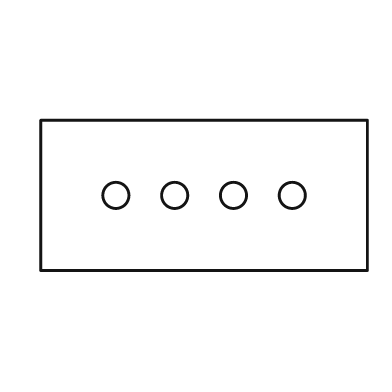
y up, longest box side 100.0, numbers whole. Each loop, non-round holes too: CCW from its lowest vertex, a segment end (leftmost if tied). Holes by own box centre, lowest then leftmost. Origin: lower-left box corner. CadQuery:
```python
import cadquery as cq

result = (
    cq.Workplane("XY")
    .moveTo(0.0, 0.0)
    .lineTo(100.0, 0.0)
    .lineTo(100.0, 46.0)
    .lineTo(0.0, 46.0)
    .close()
    .moveTo(23.0, 23.0)
    .circle(4.0)
    .moveTo(41.0, 23.0)
    .circle(4.0)
    .moveTo(59.0, 23.0)
    .circle(4.0)
    .moveTo(77.0, 23.0)
    .circle(4.0)
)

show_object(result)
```